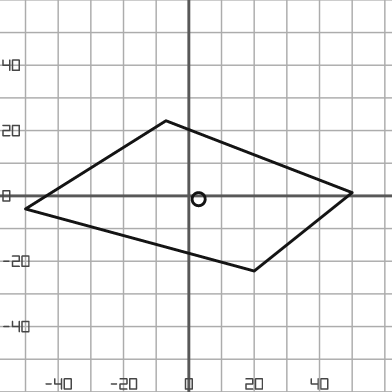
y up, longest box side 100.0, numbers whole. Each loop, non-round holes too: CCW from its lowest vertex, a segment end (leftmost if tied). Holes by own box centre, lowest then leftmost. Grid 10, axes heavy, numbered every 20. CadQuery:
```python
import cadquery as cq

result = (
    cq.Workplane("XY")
    .moveTo(20.0, -23.0)
    .lineTo(50.0, 1.0)
    .lineTo(-7.0, 23.0)
    .lineTo(-50.0, -4.0)
    .close()
    .moveTo(3.0, -1.0)
    .circle(2.0)
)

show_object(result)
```